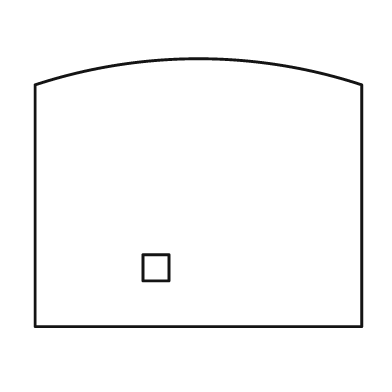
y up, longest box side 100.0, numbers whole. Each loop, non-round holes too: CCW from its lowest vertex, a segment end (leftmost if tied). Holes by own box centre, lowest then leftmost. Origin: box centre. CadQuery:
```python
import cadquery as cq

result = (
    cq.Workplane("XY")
    .moveTo(-50.0, -41.0)
    .lineTo(50.0, -41.0)
    .lineTo(50.0, 33.0)
    .threePointArc((0.0, 41.0), (-50.0, 33.0))
    .close()
    .moveTo(-17.0, -27.0)
    .lineTo(-9.0, -27.0)
    .lineTo(-9.0, -19.0)
    .lineTo(-17.0, -19.0)
    .close()
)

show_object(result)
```